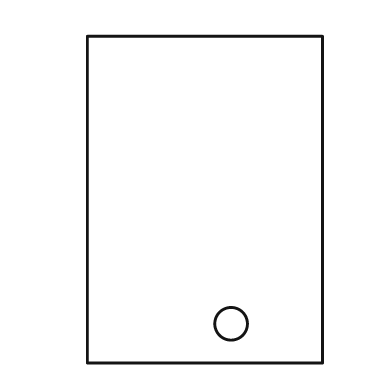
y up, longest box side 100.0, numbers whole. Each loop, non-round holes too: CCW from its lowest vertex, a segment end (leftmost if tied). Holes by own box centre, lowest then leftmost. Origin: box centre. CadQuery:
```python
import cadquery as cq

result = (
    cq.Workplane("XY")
    .moveTo(-36.0, -50.0)
    .lineTo(36.0, -50.0)
    .lineTo(36.0, 50.0)
    .lineTo(-36.0, 50.0)
    .close()
    .moveTo(8.0, -38.0)
    .circle(5.0)
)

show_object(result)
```